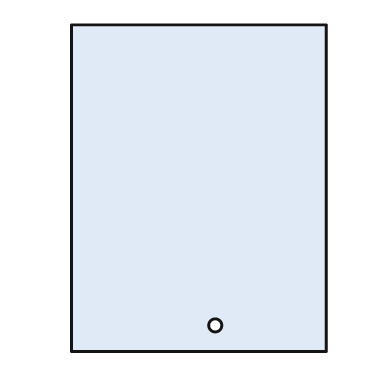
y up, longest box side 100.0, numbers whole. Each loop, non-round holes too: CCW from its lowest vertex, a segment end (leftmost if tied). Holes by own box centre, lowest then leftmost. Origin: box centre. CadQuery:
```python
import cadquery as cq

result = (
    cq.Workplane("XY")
    .moveTo(-39.0, -50.0)
    .lineTo(39.0, -50.0)
    .lineTo(39.0, 50.0)
    .lineTo(-39.0, 50.0)
    .close()
    .moveTo(5.0, -42.0)
    .circle(2.0)
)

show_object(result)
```